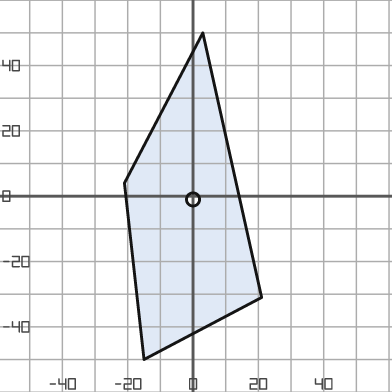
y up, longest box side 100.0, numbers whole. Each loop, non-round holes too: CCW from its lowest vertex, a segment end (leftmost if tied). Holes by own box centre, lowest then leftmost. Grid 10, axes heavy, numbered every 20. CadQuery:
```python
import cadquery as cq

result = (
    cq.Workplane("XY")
    .moveTo(-15.0, -50.0)
    .lineTo(21.0, -31.0)
    .lineTo(3.0, 50.0)
    .lineTo(-21.0, 4.0)
    .close()
    .moveTo(0.0, -1.0)
    .circle(2.0)
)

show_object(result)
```